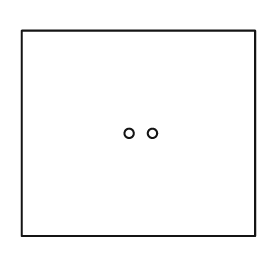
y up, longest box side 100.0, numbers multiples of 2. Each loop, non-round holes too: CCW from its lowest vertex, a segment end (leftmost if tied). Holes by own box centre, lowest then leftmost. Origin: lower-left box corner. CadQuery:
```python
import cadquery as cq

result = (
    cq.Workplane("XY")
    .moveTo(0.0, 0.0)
    .lineTo(100.0, 0.0)
    .lineTo(100.0, 88.0)
    .lineTo(0.0, 88.0)
    .close()
    .moveTo(46.0, 44.0)
    .circle(2.0)
    .moveTo(56.0, 44.0)
    .circle(2.0)
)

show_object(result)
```